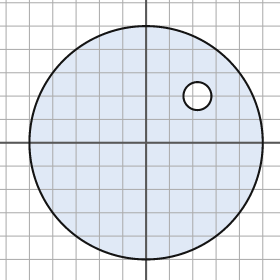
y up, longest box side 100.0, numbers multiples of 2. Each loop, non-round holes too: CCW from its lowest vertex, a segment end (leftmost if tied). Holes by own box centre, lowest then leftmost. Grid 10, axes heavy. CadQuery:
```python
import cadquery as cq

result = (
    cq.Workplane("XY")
    .moveTo(0.0, 0.0)
    .circle(50.0)
    .moveTo(22.0, 20.0)
    .circle(6.0)
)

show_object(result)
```